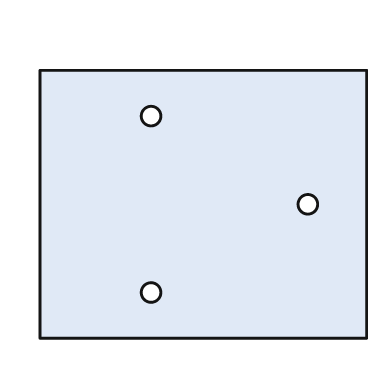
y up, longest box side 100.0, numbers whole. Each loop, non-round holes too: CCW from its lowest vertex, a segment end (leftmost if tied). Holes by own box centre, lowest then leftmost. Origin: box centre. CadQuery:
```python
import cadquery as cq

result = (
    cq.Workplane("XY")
    .moveTo(-50.0, -41.0)
    .lineTo(50.0, -41.0)
    .lineTo(50.0, 41.0)
    .lineTo(-50.0, 41.0)
    .close()
    .moveTo(-16.0, -27.0)
    .circle(3.0)
    .moveTo(32.0, 0.0)
    .circle(3.0)
    .moveTo(-16.0, 27.0)
    .circle(3.0)
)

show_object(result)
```